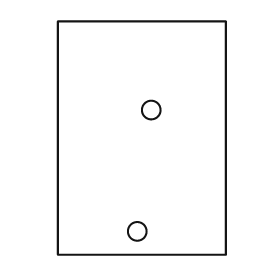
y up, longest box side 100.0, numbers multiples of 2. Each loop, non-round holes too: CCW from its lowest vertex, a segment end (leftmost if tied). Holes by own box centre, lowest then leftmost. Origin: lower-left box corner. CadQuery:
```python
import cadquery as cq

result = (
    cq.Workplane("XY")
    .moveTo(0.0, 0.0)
    .lineTo(72.0, 0.0)
    .lineTo(72.0, 100.0)
    .lineTo(0.0, 100.0)
    .close()
    .moveTo(34.0, 10.0)
    .circle(4.0)
    .moveTo(40.0, 62.0)
    .circle(4.0)
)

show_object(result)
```